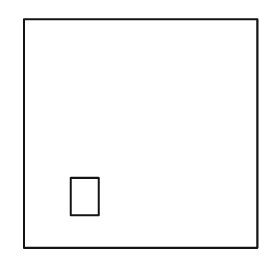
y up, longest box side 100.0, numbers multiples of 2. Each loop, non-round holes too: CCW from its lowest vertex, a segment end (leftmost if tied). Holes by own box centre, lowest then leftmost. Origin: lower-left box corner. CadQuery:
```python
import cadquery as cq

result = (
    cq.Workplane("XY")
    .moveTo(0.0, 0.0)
    .lineTo(100.0, 0.0)
    .lineTo(100.0, 98.0)
    .lineTo(0.0, 98.0)
    .close()
    .moveTo(20.0, 14.0)
    .lineTo(32.0, 14.0)
    .lineTo(32.0, 30.0)
    .lineTo(20.0, 30.0)
    .close()
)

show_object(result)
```